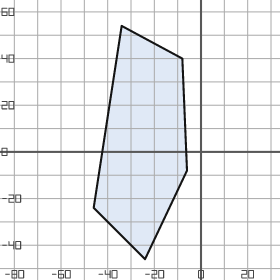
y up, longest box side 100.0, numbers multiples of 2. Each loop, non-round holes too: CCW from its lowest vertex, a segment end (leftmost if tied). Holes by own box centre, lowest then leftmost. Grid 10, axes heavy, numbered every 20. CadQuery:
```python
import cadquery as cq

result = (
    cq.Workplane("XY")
    .moveTo(-24.0, -46.0)
    .lineTo(-6.0, -8.0)
    .lineTo(-8.0, 40.0)
    .lineTo(-34.0, 54.0)
    .lineTo(-46.0, -24.0)
    .close()
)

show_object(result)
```